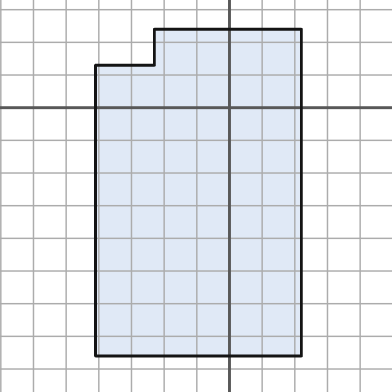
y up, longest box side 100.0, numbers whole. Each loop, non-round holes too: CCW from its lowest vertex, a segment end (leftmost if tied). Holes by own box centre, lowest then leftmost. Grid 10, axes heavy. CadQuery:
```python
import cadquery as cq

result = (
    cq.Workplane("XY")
    .moveTo(-41.0, -76.0)
    .lineTo(22.0, -76.0)
    .lineTo(22.0, 24.0)
    .lineTo(-23.0, 24.0)
    .lineTo(-23.0, 13.0)
    .lineTo(-41.0, 13.0)
    .close()
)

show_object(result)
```